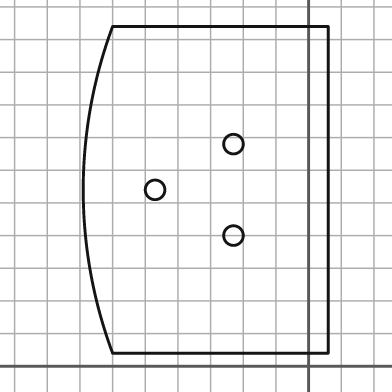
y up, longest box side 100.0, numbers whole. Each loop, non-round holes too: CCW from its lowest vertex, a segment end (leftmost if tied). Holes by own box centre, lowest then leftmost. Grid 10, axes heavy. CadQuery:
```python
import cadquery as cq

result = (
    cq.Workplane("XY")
    .moveTo(-60.0, 4.0)
    .lineTo(6.0, 4.0)
    .lineTo(6.0, 104.0)
    .lineTo(-60.0, 104.0)
    .threePointArc((-69.0, 54.0), (-60.0, 4.0))
    .close()
    .moveTo(-23.0, 40.0)
    .circle(3.0)
    .moveTo(-47.0, 54.0)
    .circle(3.0)
    .moveTo(-23.0, 68.0)
    .circle(3.0)
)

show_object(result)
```